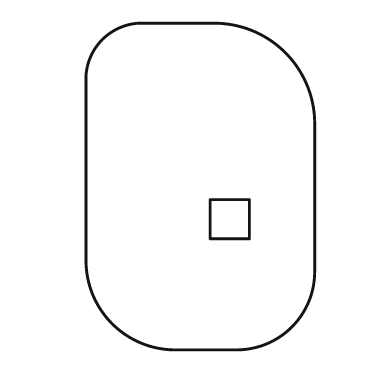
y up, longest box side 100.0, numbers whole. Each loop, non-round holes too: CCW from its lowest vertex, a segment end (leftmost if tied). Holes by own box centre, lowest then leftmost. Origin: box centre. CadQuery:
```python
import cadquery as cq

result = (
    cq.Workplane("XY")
    .moveTo(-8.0, -50.0)
    .lineTo(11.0, -50.0)
    .threePointArc((28.0, -43.0), (35.0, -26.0))
    .lineTo(35.0, 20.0)
    .threePointArc((26.0, 41.0), (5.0, 50.0))
    .lineTo(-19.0, 50.0)
    .threePointArc((-30.0, 45.0), (-35.0, 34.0))
    .lineTo(-35.0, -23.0)
    .threePointArc((-27.0, -42.0), (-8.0, -50.0))
    .close()
    .moveTo(3.0, -16.0)
    .lineTo(15.0, -16.0)
    .lineTo(15.0, -4.0)
    .lineTo(3.0, -4.0)
    .close()
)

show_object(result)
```